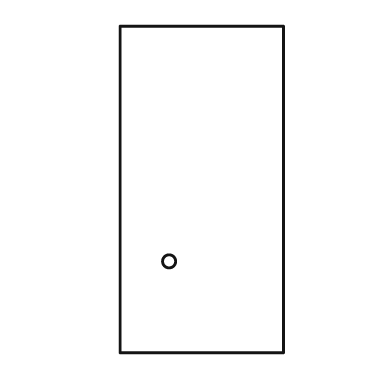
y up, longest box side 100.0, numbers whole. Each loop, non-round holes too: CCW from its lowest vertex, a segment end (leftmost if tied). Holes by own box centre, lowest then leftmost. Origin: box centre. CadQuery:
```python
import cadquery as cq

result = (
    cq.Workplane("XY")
    .moveTo(-25.0, -50.0)
    .lineTo(25.0, -50.0)
    .lineTo(25.0, 50.0)
    .lineTo(-25.0, 50.0)
    .close()
    .moveTo(-10.0, -22.0)
    .circle(2.0)
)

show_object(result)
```